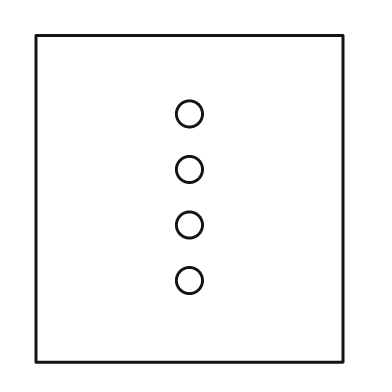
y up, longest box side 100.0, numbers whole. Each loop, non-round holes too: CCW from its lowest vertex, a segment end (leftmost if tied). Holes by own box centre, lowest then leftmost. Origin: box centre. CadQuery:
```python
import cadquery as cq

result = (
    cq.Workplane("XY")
    .moveTo(-47.0, -50.0)
    .lineTo(47.0, -50.0)
    .lineTo(47.0, 50.0)
    .lineTo(-47.0, 50.0)
    .close()
    .moveTo(0.0, -25.0)
    .circle(4.0)
    .moveTo(0.0, -8.0)
    .circle(4.0)
    .moveTo(0.0, 9.0)
    .circle(4.0)
    .moveTo(0.0, 26.0)
    .circle(4.0)
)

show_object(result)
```